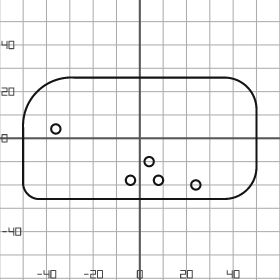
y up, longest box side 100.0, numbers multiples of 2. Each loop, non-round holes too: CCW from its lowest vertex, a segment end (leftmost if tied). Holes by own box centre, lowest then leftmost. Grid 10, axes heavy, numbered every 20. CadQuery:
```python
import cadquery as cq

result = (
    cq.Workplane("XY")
    .moveTo(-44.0, -26.0)
    .lineTo(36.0, -26.0)
    .threePointArc((46.0, -22.0), (50.0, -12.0))
    .lineTo(50.0, 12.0)
    .threePointArc((46.0, 22.0), (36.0, 26.0))
    .lineTo(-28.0, 26.0)
    .threePointArc((-44.0, 20.0), (-50.0, 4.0))
    .lineTo(-50.0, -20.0)
    .threePointArc((-48.0, -24.0), (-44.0, -26.0))
    .close()
    .moveTo(24.0, -20.0)
    .circle(2.0)
    .moveTo(-4.0, -18.0)
    .circle(2.0)
    .moveTo(8.0, -18.0)
    .circle(2.0)
    .moveTo(4.0, -10.0)
    .circle(2.0)
    .moveTo(-36.0, 4.0)
    .circle(2.0)
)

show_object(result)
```